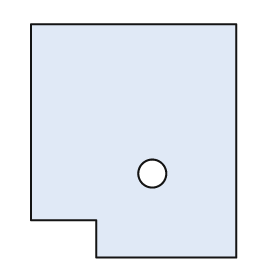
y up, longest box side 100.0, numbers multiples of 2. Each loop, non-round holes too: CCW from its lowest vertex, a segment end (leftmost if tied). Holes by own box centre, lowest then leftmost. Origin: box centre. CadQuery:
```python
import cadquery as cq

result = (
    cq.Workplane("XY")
    .moveTo(-16.0, -50.0)
    .lineTo(44.0, -50.0)
    .lineTo(44.0, 50.0)
    .lineTo(-44.0, 50.0)
    .lineTo(-44.0, -34.0)
    .lineTo(-16.0, -34.0)
    .close()
    .moveTo(8.0, -14.0)
    .circle(6.0)
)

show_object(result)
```